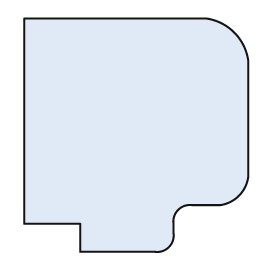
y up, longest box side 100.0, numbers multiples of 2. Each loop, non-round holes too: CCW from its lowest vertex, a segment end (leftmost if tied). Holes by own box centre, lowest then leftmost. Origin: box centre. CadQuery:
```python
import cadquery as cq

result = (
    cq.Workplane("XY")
    .moveTo(-24.0, -50.0)
    .lineTo(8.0, -50.0)
    .threePointArc((14.0, -48.0), (16.0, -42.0))
    .lineTo(16.0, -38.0)
    .threePointArc((18.0, -32.0), (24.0, -30.0))
    .lineTo(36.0, -30.0)
    .threePointArc((44.0, -26.0), (48.0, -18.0))
    .lineTo(48.0, 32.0)
    .threePointArc((42.0, 44.0), (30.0, 50.0))
    .lineTo(-48.0, 50.0)
    .lineTo(-48.0, -38.0)
    .lineTo(-24.0, -38.0)
    .close()
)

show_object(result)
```